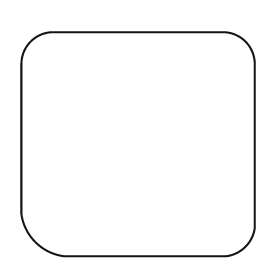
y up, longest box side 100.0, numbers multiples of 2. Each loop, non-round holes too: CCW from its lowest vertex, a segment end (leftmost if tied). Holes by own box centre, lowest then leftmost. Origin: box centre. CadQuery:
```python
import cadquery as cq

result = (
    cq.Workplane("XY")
    .moveTo(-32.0, -48.0)
    .lineTo(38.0, -48.0)
    .threePointArc((46.0, -44.0), (50.0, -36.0))
    .lineTo(50.0, 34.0)
    .threePointArc((46.0, 44.0), (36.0, 48.0))
    .lineTo(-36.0, 48.0)
    .threePointArc((-46.0, 44.0), (-50.0, 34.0))
    .lineTo(-50.0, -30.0)
    .threePointArc((-44.0, -42.0), (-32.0, -48.0))
    .close()
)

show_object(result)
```